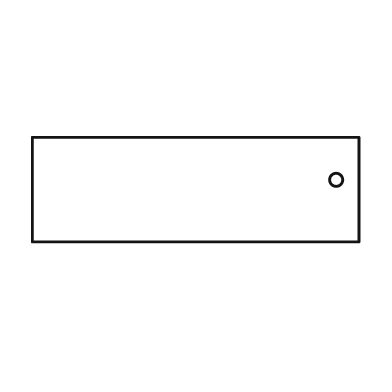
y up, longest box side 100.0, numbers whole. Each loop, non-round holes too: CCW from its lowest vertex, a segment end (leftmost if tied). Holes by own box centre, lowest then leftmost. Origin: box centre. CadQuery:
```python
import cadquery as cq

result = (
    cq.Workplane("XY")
    .moveTo(-50.0, -16.0)
    .lineTo(50.0, -16.0)
    .lineTo(50.0, 16.0)
    .lineTo(-50.0, 16.0)
    .close()
    .moveTo(43.0, 3.0)
    .circle(2.0)
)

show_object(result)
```